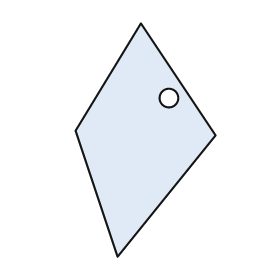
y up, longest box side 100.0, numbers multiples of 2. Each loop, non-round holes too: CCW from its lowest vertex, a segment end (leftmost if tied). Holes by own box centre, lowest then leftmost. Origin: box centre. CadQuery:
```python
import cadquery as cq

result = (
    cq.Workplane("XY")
    .moveTo(-12.0, -50.0)
    .lineTo(30.0, 2.0)
    .lineTo(-2.0, 50.0)
    .lineTo(-30.0, 4.0)
    .close()
    .moveTo(10.0, 18.0)
    .circle(4.0)
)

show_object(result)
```